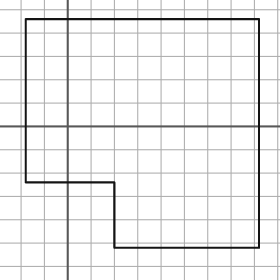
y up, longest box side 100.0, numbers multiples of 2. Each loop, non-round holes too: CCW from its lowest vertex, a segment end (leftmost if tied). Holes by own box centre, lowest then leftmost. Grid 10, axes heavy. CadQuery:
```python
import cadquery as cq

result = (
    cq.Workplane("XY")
    .moveTo(20.0, -52.0)
    .lineTo(82.0, -52.0)
    .lineTo(82.0, 46.0)
    .lineTo(-18.0, 46.0)
    .lineTo(-18.0, -24.0)
    .lineTo(20.0, -24.0)
    .close()
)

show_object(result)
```